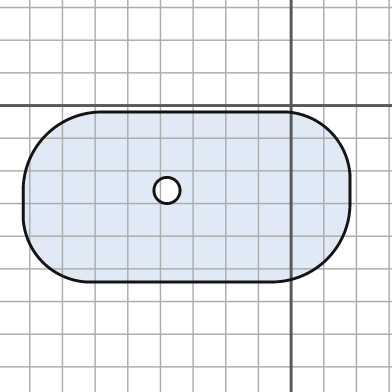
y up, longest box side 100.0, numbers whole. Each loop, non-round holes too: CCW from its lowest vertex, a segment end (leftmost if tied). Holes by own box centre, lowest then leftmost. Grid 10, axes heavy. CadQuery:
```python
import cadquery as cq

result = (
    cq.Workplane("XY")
    .moveTo(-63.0, -54.0)
    .lineTo(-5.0, -54.0)
    .threePointArc((11.0, -47.0), (18.0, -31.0))
    .lineTo(18.0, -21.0)
    .threePointArc((12.0, -8.0), (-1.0, -2.0))
    .lineTo(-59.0, -2.0)
    .threePointArc((-75.0, -9.0), (-82.0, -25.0))
    .lineTo(-82.0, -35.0)
    .threePointArc((-76.0, -48.0), (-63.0, -54.0))
    .close()
    .moveTo(-38.0, -26.0)
    .circle(4.0)
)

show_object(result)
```